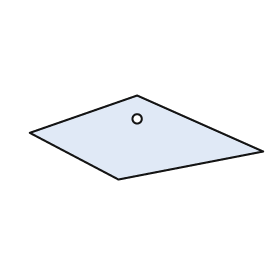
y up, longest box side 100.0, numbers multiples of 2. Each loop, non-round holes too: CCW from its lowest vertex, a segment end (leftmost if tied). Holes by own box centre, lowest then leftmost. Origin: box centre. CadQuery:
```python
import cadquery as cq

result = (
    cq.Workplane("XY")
    .moveTo(-12.0, -18.0)
    .lineTo(50.0, -6.0)
    .lineTo(-4.0, 18.0)
    .lineTo(-50.0, 2.0)
    .close()
    .moveTo(-4.0, 8.0)
    .circle(2.0)
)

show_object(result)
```